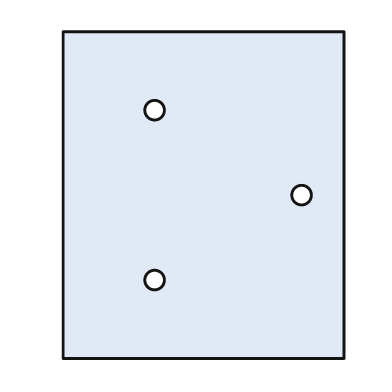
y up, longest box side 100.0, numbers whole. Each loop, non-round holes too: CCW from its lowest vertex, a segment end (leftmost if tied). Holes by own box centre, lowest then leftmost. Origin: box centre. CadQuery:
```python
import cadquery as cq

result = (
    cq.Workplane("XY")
    .moveTo(-43.0, -50.0)
    .lineTo(43.0, -50.0)
    .lineTo(43.0, 50.0)
    .lineTo(-43.0, 50.0)
    .close()
    .moveTo(-15.0, -26.0)
    .circle(3.0)
    .moveTo(30.0, 0.0)
    .circle(3.0)
    .moveTo(-15.0, 26.0)
    .circle(3.0)
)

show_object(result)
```